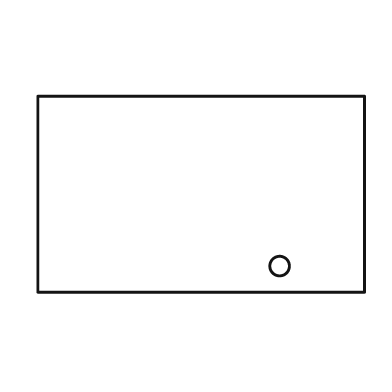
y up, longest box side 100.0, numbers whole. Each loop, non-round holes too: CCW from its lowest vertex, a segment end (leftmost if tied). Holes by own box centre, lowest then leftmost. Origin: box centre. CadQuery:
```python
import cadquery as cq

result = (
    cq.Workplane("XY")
    .moveTo(-50.0, -30.0)
    .lineTo(50.0, -30.0)
    .lineTo(50.0, 30.0)
    .lineTo(-50.0, 30.0)
    .close()
    .moveTo(24.0, -22.0)
    .circle(3.0)
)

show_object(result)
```